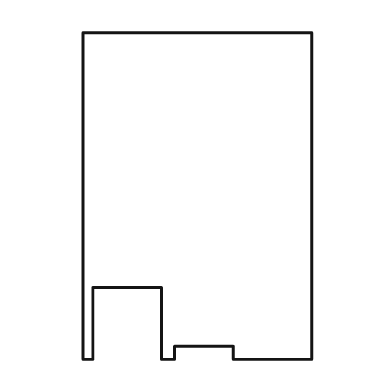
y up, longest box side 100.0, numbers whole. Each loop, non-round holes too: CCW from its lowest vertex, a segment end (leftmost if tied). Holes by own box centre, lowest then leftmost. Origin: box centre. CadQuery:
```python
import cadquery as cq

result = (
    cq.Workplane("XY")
    .moveTo(-35.0, -50.0)
    .lineTo(-32.0, -50.0)
    .lineTo(-32.0, -28.0)
    .lineTo(-11.0, -28.0)
    .lineTo(-11.0, -50.0)
    .lineTo(-7.0, -50.0)
    .lineTo(-7.0, -46.0)
    .lineTo(11.0, -46.0)
    .lineTo(11.0, -50.0)
    .lineTo(35.0, -50.0)
    .lineTo(35.0, 50.0)
    .lineTo(-35.0, 50.0)
    .close()
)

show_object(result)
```